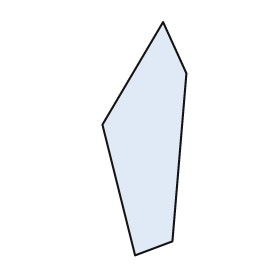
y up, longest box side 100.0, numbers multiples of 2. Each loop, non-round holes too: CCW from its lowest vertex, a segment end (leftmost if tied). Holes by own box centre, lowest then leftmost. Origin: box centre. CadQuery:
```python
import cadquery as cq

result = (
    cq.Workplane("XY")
    .moveTo(-4.0, -50.0)
    .lineTo(12.0, -44.0)
    .lineTo(18.0, 28.0)
    .lineTo(8.0, 50.0)
    .lineTo(-18.0, 6.0)
    .close()
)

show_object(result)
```